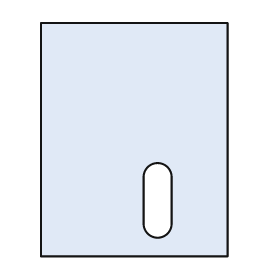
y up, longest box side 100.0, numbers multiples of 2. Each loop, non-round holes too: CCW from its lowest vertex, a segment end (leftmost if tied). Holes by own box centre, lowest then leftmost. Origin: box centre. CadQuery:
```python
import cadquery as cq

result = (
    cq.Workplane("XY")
    .moveTo(-40.0, -50.0)
    .lineTo(40.0, -50.0)
    .lineTo(40.0, 50.0)
    .lineTo(-40.0, 50.0)
    .close()
    .moveTo(4.0, -36.0)
    .threePointArc((10.0, -42.0), (16.0, -36.0))
    .lineTo(16.0, -16.0)
    .threePointArc((10.0, -10.0), (4.0, -16.0))
    .close()
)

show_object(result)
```